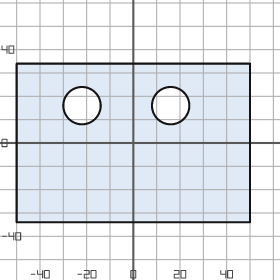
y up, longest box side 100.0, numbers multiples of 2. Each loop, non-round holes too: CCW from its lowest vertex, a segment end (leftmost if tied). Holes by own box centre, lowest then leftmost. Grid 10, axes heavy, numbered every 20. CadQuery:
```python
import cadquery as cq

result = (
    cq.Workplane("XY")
    .moveTo(-50.0, -34.0)
    .lineTo(50.0, -34.0)
    .lineTo(50.0, 34.0)
    .lineTo(-50.0, 34.0)
    .close()
    .moveTo(-22.0, 16.0)
    .circle(8.0)
    .moveTo(16.0, 16.0)
    .circle(8.0)
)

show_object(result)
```